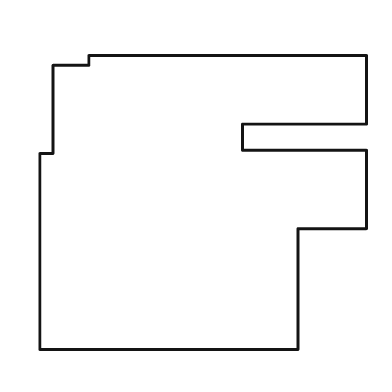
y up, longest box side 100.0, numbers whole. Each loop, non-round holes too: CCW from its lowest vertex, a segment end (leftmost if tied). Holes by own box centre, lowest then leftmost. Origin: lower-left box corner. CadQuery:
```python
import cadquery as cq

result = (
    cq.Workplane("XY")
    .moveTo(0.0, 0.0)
    .lineTo(79.0, 0.0)
    .lineTo(79.0, 37.0)
    .lineTo(100.0, 37.0)
    .lineTo(100.0, 61.0)
    .lineTo(62.0, 61.0)
    .lineTo(62.0, 69.0)
    .lineTo(100.0, 69.0)
    .lineTo(100.0, 90.0)
    .lineTo(15.0, 90.0)
    .lineTo(15.0, 87.0)
    .lineTo(4.0, 87.0)
    .lineTo(4.0, 60.0)
    .lineTo(0.0, 60.0)
    .close()
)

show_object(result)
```